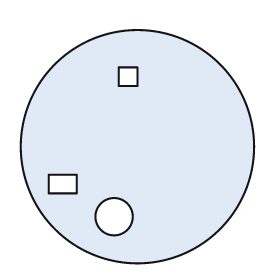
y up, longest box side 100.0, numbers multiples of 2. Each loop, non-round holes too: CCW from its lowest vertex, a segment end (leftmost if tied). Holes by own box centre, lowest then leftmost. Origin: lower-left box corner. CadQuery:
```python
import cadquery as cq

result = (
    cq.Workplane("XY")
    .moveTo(50.0, 50.0)
    .circle(50.0)
    .moveTo(40.0, 20.0)
    .circle(8.0)
    .moveTo(12.0, 30.0)
    .lineTo(24.0, 30.0)
    .lineTo(24.0, 38.0)
    .lineTo(12.0, 38.0)
    .close()
    .moveTo(42.0, 76.0)
    .lineTo(50.0, 76.0)
    .lineTo(50.0, 84.0)
    .lineTo(42.0, 84.0)
    .close()
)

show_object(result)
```